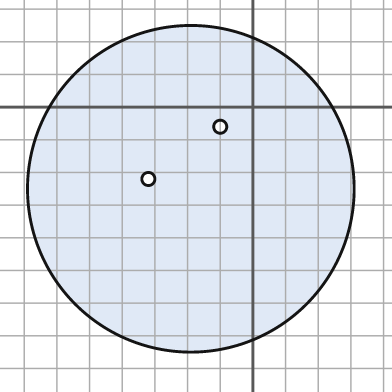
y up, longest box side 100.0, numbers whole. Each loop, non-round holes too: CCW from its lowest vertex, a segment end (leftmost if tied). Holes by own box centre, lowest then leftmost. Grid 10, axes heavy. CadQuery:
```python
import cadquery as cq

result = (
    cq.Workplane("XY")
    .moveTo(-19.0, -25.0)
    .circle(50.0)
    .moveTo(-32.0, -22.0)
    .circle(2.0)
    .moveTo(-10.0, -6.0)
    .circle(2.0)
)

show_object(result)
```